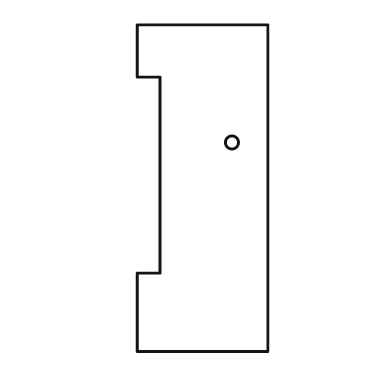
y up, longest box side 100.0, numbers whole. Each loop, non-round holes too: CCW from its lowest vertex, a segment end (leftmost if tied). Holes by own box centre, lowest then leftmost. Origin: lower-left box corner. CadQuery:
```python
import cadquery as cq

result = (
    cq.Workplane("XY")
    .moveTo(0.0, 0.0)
    .lineTo(40.0, 0.0)
    .lineTo(40.0, 100.0)
    .lineTo(0.0, 100.0)
    .lineTo(0.0, 84.0)
    .lineTo(7.0, 84.0)
    .lineTo(7.0, 24.0)
    .lineTo(0.0, 24.0)
    .close()
    .moveTo(29.0, 64.0)
    .circle(2.0)
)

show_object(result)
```